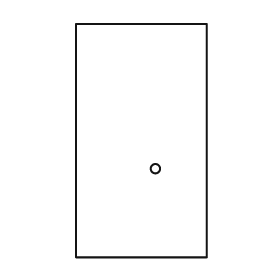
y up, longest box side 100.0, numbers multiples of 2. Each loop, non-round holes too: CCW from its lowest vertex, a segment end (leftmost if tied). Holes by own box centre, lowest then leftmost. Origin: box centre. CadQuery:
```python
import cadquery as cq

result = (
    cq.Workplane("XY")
    .moveTo(-28.0, -50.0)
    .lineTo(28.0, -50.0)
    .lineTo(28.0, 50.0)
    .lineTo(-28.0, 50.0)
    .close()
    .moveTo(6.0, -12.0)
    .circle(2.0)
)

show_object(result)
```